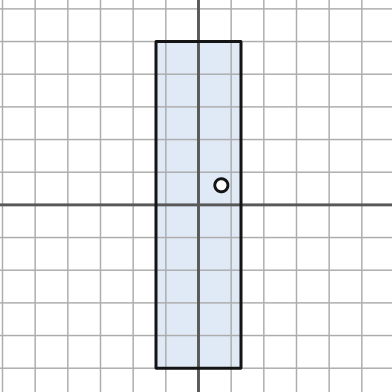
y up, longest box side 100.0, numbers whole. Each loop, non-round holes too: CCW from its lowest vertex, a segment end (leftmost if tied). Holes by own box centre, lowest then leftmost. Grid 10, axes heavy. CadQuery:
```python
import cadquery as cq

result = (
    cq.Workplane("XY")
    .moveTo(-13.0, -50.0)
    .lineTo(13.0, -50.0)
    .lineTo(13.0, 50.0)
    .lineTo(-13.0, 50.0)
    .close()
    .moveTo(7.0, 6.0)
    .circle(2.0)
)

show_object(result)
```